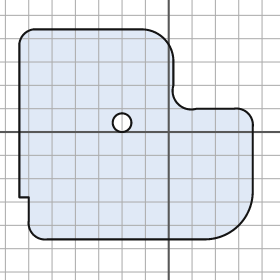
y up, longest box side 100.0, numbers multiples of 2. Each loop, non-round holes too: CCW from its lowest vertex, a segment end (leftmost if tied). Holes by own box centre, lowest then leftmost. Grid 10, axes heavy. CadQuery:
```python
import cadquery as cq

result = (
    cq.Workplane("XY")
    .moveTo(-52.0, -46.0)
    .lineTo(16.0, -46.0)
    .threePointArc((30.0, -40.0), (36.0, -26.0))
    .lineTo(36.0, 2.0)
    .threePointArc((34.0, 8.0), (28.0, 10.0))
    .lineTo(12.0, 10.0)
    .threePointArc((4.0, 12.0), (2.0, 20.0))
    .lineTo(2.0, 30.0)
    .threePointArc((-2.0, 40.0), (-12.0, 44.0))
    .lineTo(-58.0, 44.0)
    .threePointArc((-62.0, 42.0), (-64.0, 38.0))
    .lineTo(-64.0, -28.0)
    .lineTo(-60.0, -28.0)
    .lineTo(-60.0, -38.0)
    .threePointArc((-58.0, -44.0), (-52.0, -46.0))
    .close()
    .moveTo(-20.0, 4.0)
    .circle(4.0)
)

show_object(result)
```